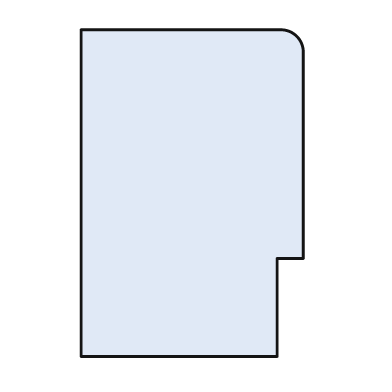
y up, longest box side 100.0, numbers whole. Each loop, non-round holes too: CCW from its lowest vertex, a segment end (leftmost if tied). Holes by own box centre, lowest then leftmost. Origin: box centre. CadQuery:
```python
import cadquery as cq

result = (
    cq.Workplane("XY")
    .moveTo(-34.0, -50.0)
    .lineTo(26.0, -50.0)
    .lineTo(26.0, -20.0)
    .lineTo(34.0, -20.0)
    .lineTo(34.0, 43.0)
    .threePointArc((32.0, 48.0), (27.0, 50.0))
    .lineTo(-34.0, 50.0)
    .close()
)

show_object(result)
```